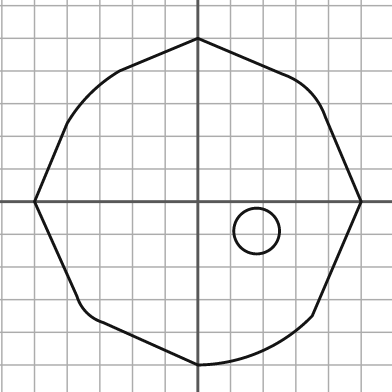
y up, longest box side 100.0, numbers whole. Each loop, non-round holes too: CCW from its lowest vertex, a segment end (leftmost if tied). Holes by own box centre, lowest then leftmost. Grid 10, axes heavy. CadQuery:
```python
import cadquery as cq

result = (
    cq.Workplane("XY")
    .moveTo(0.0, -50.0)
    .threePointArc((19.0, -46.0), (35.0, -35.0))
    .lineTo(50.0, 0.0)
    .lineTo(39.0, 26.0)
    .threePointArc((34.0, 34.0), (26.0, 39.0))
    .lineTo(0.0, 50.0)
    .lineTo(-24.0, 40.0)
    .threePointArc((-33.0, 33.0), (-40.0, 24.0))
    .lineTo(-50.0, 0.0)
    .lineTo(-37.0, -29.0)
    .threePointArc((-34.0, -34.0), (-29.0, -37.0))
    .close()
    .moveTo(18.0, -9.0)
    .circle(7.0)
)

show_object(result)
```